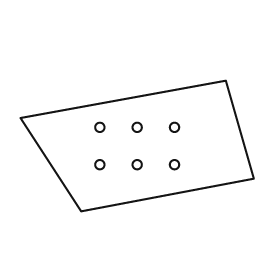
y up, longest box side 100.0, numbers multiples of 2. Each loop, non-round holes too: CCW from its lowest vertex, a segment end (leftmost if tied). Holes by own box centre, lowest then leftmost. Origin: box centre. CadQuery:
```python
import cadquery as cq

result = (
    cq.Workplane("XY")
    .moveTo(-24.0, -28.0)
    .lineTo(50.0, -14.0)
    .lineTo(38.0, 28.0)
    .lineTo(-50.0, 12.0)
    .close()
    .moveTo(-16.0, -8.0)
    .circle(2.0)
    .moveTo(0.0, -8.0)
    .circle(2.0)
    .moveTo(16.0, -8.0)
    .circle(2.0)
    .moveTo(-16.0, 8.0)
    .circle(2.0)
    .moveTo(0.0, 8.0)
    .circle(2.0)
    .moveTo(16.0, 8.0)
    .circle(2.0)
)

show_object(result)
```